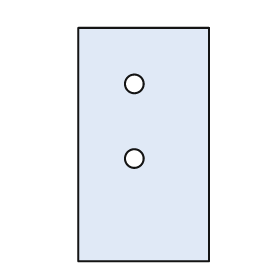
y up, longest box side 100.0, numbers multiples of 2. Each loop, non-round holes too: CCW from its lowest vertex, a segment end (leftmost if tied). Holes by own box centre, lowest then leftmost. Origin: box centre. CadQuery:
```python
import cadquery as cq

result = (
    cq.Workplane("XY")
    .moveTo(-28.0, -50.0)
    .lineTo(28.0, -50.0)
    .lineTo(28.0, 50.0)
    .lineTo(-28.0, 50.0)
    .close()
    .moveTo(-4.0, -6.0)
    .circle(4.0)
    .moveTo(-4.0, 26.0)
    .circle(4.0)
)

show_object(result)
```